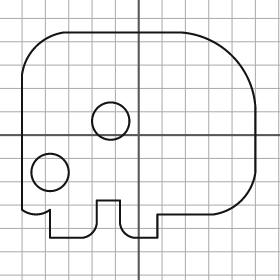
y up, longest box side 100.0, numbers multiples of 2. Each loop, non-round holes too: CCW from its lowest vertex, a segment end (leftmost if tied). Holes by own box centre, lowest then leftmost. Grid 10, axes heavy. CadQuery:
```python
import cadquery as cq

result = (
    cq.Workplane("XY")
    .moveTo(-38.0, -44.0)
    .lineTo(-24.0, -44.0)
    .threePointArc((-20.0, -42.0), (-18.0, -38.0))
    .lineTo(-18.0, -28.0)
    .lineTo(-8.0, -28.0)
    .lineTo(-8.0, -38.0)
    .threePointArc((-6.0, -42.0), (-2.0, -44.0))
    .lineTo(8.0, -44.0)
    .lineTo(8.0, -34.0)
    .lineTo(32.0, -34.0)
    .threePointArc((44.0, -28.0), (50.0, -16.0))
    .lineTo(50.0, 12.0)
    .threePointArc((40.0, 34.0), (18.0, 44.0))
    .lineTo(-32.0, 44.0)
    .threePointArc((-44.0, 38.0), (-50.0, 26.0))
    .lineTo(-50.0, -32.0)
    .threePointArc((-44.0, -34.0), (-38.0, -32.0))
    .close()
    .moveTo(-38.0, -16.0)
    .circle(8.0)
    .moveTo(-12.0, 6.0)
    .circle(8.0)
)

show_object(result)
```